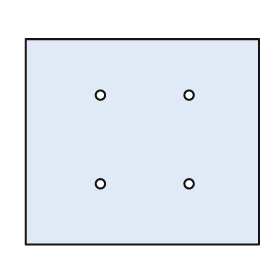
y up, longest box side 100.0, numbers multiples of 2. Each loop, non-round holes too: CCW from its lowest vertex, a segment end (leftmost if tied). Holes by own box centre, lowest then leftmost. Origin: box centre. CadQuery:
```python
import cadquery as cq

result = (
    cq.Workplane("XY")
    .moveTo(-50.0, -44.0)
    .lineTo(50.0, -44.0)
    .lineTo(50.0, 44.0)
    .lineTo(-50.0, 44.0)
    .close()
    .moveTo(-18.0, -18.0)
    .circle(2.0)
    .moveTo(20.0, -18.0)
    .circle(2.0)
    .moveTo(-18.0, 20.0)
    .circle(2.0)
    .moveTo(20.0, 20.0)
    .circle(2.0)
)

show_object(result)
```